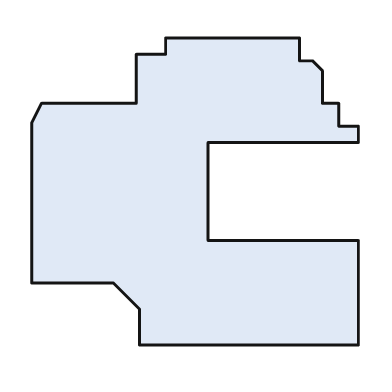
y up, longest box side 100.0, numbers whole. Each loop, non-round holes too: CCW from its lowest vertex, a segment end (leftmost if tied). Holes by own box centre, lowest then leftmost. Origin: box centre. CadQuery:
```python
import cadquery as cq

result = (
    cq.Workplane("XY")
    .moveTo(-17.0, -47.0)
    .lineTo(50.0, -47.0)
    .lineTo(50.0, -15.0)
    .lineTo(4.0, -15.0)
    .lineTo(4.0, 15.0)
    .lineTo(50.0, 15.0)
    .lineTo(50.0, 20.0)
    .lineTo(44.0, 20.0)
    .lineTo(44.0, 27.0)
    .lineTo(39.0, 27.0)
    .lineTo(39.0, 37.0)
    .lineTo(36.0, 40.0)
    .lineTo(32.0, 40.0)
    .lineTo(32.0, 47.0)
    .lineTo(-9.0, 47.0)
    .lineTo(-9.0, 42.0)
    .lineTo(-18.0, 42.0)
    .lineTo(-18.0, 27.0)
    .lineTo(-47.0, 27.0)
    .lineTo(-50.0, 21.0)
    .lineTo(-50.0, -28.0)
    .lineTo(-25.0, -28.0)
    .lineTo(-17.0, -36.0)
    .close()
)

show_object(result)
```